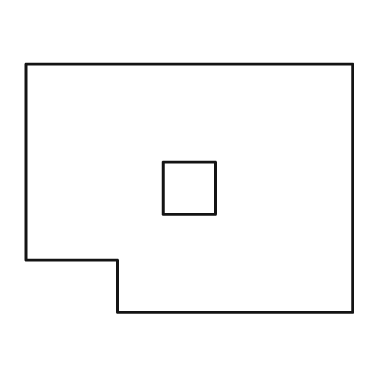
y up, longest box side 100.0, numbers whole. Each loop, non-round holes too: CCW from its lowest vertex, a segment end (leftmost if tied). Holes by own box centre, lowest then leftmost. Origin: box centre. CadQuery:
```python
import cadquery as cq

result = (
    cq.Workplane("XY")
    .moveTo(-22.0, -38.0)
    .lineTo(50.0, -38.0)
    .lineTo(50.0, 38.0)
    .lineTo(-50.0, 38.0)
    .lineTo(-50.0, -22.0)
    .lineTo(-22.0, -22.0)
    .close()
    .moveTo(-8.0, -8.0)
    .lineTo(8.0, -8.0)
    .lineTo(8.0, 8.0)
    .lineTo(-8.0, 8.0)
    .close()
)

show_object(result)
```